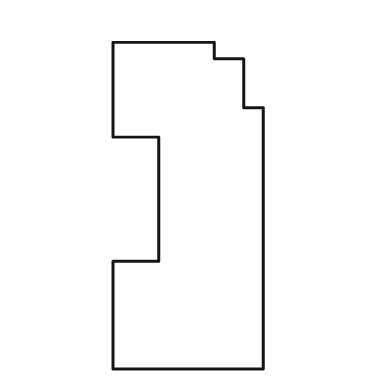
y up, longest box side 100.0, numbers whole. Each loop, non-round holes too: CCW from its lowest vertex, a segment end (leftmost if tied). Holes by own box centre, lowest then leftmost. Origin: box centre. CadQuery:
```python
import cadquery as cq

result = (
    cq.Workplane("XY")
    .moveTo(-23.0, -50.0)
    .lineTo(23.0, -50.0)
    .lineTo(23.0, 30.0)
    .lineTo(17.0, 30.0)
    .lineTo(17.0, 45.0)
    .lineTo(8.0, 45.0)
    .lineTo(8.0, 50.0)
    .lineTo(-23.0, 50.0)
    .lineTo(-23.0, 21.0)
    .lineTo(-9.0, 21.0)
    .lineTo(-9.0, -17.0)
    .lineTo(-23.0, -17.0)
    .close()
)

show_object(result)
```